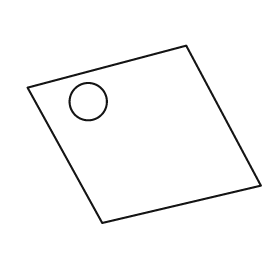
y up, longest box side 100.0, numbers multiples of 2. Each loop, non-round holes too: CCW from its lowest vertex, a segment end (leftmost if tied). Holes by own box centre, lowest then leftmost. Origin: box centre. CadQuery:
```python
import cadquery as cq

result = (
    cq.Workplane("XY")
    .moveTo(-18.0, -38.0)
    .lineTo(50.0, -22.0)
    .lineTo(18.0, 38.0)
    .lineTo(-50.0, 20.0)
    .close()
    .moveTo(-24.0, 14.0)
    .circle(8.0)
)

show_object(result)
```